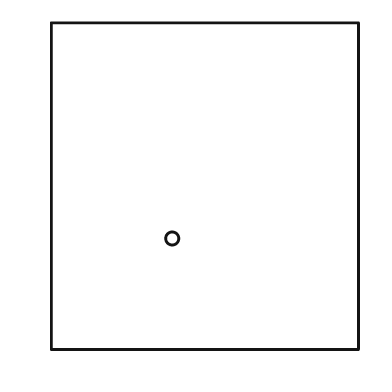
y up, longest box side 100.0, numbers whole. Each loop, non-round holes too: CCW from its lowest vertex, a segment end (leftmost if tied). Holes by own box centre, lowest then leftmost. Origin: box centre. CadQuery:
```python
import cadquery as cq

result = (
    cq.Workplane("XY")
    .moveTo(-47.0, -50.0)
    .lineTo(47.0, -50.0)
    .lineTo(47.0, 50.0)
    .lineTo(-47.0, 50.0)
    .close()
    .moveTo(-10.0, -16.0)
    .circle(2.0)
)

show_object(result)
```